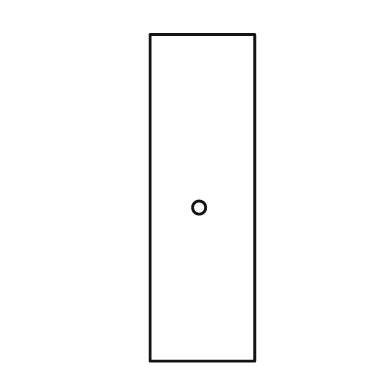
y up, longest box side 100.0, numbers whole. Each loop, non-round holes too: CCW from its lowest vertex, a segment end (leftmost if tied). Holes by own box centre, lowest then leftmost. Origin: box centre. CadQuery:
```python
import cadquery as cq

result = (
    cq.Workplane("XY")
    .moveTo(-16.0, -50.0)
    .lineTo(16.0, -50.0)
    .lineTo(16.0, 50.0)
    .lineTo(-16.0, 50.0)
    .close()
    .moveTo(-1.0, -3.0)
    .circle(2.0)
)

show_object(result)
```